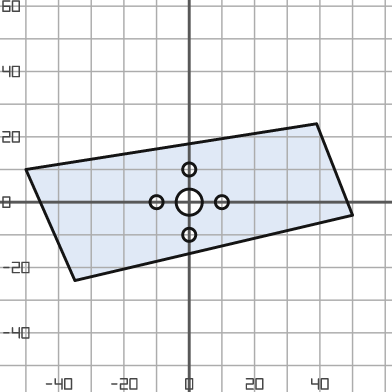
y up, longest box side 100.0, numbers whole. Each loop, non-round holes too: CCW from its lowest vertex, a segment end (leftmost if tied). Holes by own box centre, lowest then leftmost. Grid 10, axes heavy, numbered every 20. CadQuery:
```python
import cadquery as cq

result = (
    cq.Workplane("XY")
    .moveTo(-35.0, -24.0)
    .lineTo(50.0, -4.0)
    .lineTo(39.0, 24.0)
    .lineTo(-50.0, 10.0)
    .close()
    .moveTo(0.0, -10.0)
    .circle(2.0)
    .moveTo(-10.0, 0.0)
    .circle(2.0)
    .moveTo(0.0, 0.0)
    .circle(4.0)
    .moveTo(10.0, 0.0)
    .circle(2.0)
    .moveTo(0.0, 10.0)
    .circle(2.0)
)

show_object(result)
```